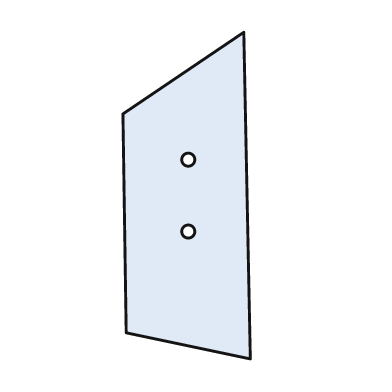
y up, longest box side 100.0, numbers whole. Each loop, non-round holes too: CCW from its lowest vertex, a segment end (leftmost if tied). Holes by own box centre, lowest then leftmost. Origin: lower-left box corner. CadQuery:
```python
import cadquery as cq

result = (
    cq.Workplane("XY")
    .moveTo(39.0, 0.0)
    .lineTo(37.0, 100.0)
    .lineTo(0.0, 75.0)
    .lineTo(1.0, 8.0)
    .close()
    .moveTo(20.0, 39.0)
    .circle(2.0)
    .moveTo(20.0, 61.0)
    .circle(2.0)
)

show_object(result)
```